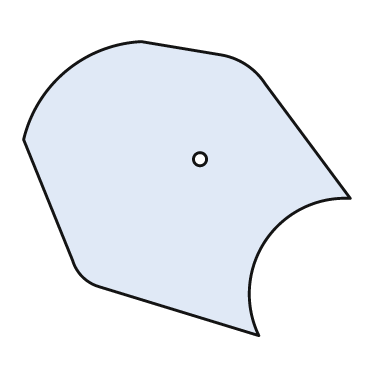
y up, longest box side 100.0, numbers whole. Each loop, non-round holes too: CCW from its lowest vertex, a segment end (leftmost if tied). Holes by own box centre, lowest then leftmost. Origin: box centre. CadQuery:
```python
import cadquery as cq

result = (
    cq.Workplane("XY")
    .moveTo(22.0, -45.0)
    .threePointArc((24.0, -16.0), (50.0, -3.0))
    .lineTo(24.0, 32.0)
    .threePointArc((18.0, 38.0), (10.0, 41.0))
    .lineTo(-14.0, 45.0)
    .threePointArc((-37.0, 36.0), (-50.0, 15.0))
    .lineTo(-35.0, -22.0)
    .threePointArc((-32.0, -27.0), (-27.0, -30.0))
    .close()
    .moveTo(4.0, 9.0)
    .circle(2.0)
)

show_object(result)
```